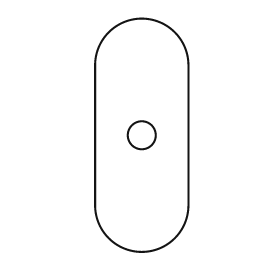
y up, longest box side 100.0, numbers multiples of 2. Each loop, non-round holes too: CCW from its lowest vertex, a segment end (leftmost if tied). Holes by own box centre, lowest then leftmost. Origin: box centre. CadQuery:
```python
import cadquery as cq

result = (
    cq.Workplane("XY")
    .moveTo(-20.0, -30.0)
    .threePointArc((0.0, -50.0), (20.0, -30.0))
    .lineTo(20.0, 30.0)
    .threePointArc((0.0, 50.0), (-20.0, 30.0))
    .close()
    .moveTo(0.0, 0.0)
    .circle(6.0)
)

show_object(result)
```